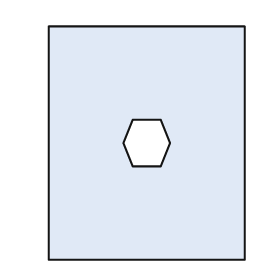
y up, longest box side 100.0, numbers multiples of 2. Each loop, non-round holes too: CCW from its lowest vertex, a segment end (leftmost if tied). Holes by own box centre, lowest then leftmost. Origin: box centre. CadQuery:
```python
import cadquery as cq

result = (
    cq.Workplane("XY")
    .moveTo(-42.0, -50.0)
    .lineTo(42.0, -50.0)
    .lineTo(42.0, 50.0)
    .lineTo(-42.0, 50.0)
    .close()
    .moveTo(-6.0, -10.0)
    .lineTo(6.0, -10.0)
    .lineTo(10.0, 0.0)
    .lineTo(6.0, 10.0)
    .lineTo(-6.0, 10.0)
    .lineTo(-10.0, 0.0)
    .close()
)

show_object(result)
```